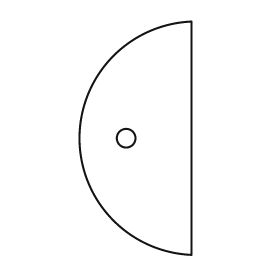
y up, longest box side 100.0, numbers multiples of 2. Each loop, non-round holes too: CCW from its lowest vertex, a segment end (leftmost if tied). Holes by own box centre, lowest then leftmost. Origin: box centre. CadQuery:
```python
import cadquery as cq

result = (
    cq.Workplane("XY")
    .moveTo(24.0, -50.0)
    .lineTo(24.0, 50.0)
    .threePointArc((-24.0, 0.0), (24.0, -50.0))
    .close()
    .moveTo(-4.0, 0.0)
    .circle(4.0)
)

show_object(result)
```